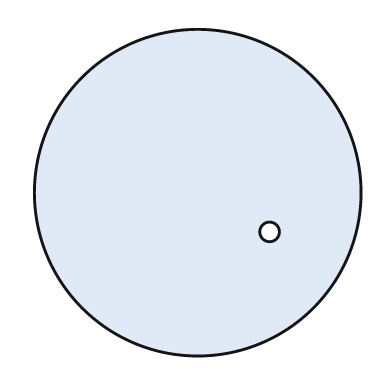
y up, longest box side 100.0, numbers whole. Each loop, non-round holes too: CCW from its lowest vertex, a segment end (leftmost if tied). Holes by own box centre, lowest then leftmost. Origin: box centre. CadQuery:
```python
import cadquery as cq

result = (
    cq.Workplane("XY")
    .moveTo(0.0, 0.0)
    .circle(50.0)
    .moveTo(22.0, -12.0)
    .circle(3.0)
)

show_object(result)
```